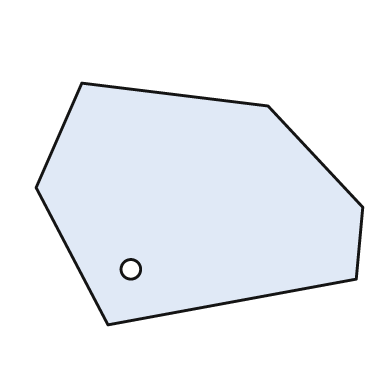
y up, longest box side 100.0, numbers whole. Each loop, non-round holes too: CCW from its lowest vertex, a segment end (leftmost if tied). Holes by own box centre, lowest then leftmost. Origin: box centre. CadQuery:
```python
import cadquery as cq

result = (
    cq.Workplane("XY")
    .moveTo(-28.0, -37.0)
    .lineTo(48.0, -23.0)
    .lineTo(50.0, -1.0)
    .lineTo(21.0, 30.0)
    .lineTo(-36.0, 37.0)
    .lineTo(-50.0, 5.0)
    .close()
    .moveTo(-21.0, -20.0)
    .circle(3.0)
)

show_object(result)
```